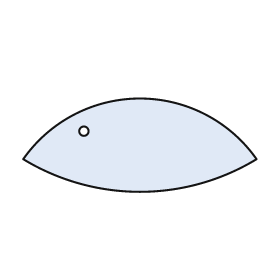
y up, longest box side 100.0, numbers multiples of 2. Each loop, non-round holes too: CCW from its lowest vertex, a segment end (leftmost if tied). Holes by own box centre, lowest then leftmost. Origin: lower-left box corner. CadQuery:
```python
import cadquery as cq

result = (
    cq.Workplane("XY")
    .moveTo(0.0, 14.0)
    .threePointArc((50.0, 0.0), (100.0, 14.0))
    .threePointArc((50.0, 40.0), (0.0, 14.0))
    .close()
    .moveTo(26.0, 26.0)
    .circle(2.0)
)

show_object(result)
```